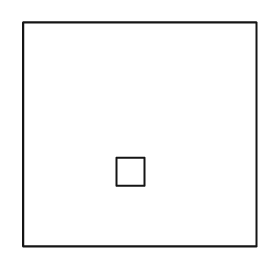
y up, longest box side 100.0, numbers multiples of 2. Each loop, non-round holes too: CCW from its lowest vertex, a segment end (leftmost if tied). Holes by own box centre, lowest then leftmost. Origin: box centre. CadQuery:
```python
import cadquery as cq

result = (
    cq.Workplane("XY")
    .moveTo(-50.0, -48.0)
    .lineTo(50.0, -48.0)
    .lineTo(50.0, 48.0)
    .lineTo(-50.0, 48.0)
    .close()
    .moveTo(-10.0, -22.0)
    .lineTo(2.0, -22.0)
    .lineTo(2.0, -10.0)
    .lineTo(-10.0, -10.0)
    .close()
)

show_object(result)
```